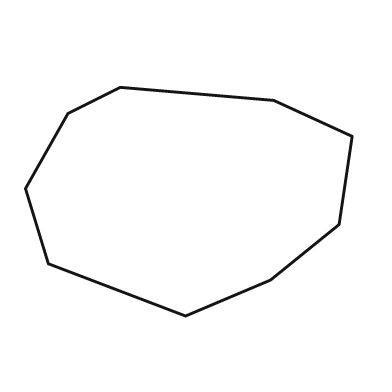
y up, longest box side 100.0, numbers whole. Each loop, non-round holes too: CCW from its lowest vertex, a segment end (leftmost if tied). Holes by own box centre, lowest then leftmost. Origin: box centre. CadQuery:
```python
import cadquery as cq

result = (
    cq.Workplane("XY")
    .moveTo(-1.0, -35.0)
    .lineTo(25.0, -24.0)
    .lineTo(46.0, -7.0)
    .lineTo(50.0, 20.0)
    .lineTo(26.0, 31.0)
    .lineTo(-21.0, 35.0)
    .lineTo(-37.0, 27.0)
    .lineTo(-50.0, 4.0)
    .lineTo(-43.0, -19.0)
    .close()
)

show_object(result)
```